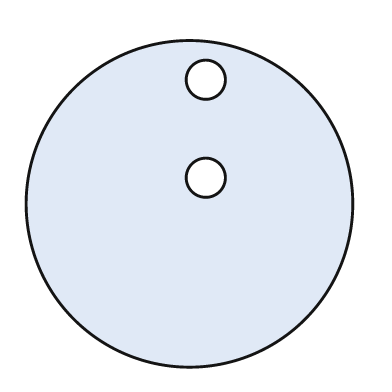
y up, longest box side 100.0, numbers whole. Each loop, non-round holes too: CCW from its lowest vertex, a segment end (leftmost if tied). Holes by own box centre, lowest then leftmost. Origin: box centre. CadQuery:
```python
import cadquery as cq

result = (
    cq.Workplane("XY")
    .moveTo(0.0, 0.0)
    .circle(50.0)
    .moveTo(5.0, 8.0)
    .circle(6.0)
    .moveTo(5.0, 38.0)
    .circle(6.0)
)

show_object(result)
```